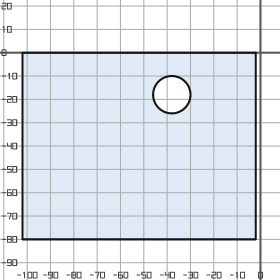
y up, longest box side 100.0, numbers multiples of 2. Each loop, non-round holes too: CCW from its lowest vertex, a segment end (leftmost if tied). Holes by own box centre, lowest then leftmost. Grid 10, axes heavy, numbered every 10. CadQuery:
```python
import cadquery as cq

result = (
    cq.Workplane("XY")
    .moveTo(-102.0, -80.0)
    .lineTo(-2.0, -80.0)
    .lineTo(-2.0, 0.0)
    .lineTo(-102.0, 0.0)
    .close()
    .moveTo(-38.0, -18.0)
    .circle(8.0)
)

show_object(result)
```